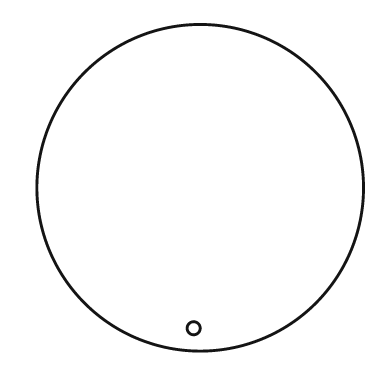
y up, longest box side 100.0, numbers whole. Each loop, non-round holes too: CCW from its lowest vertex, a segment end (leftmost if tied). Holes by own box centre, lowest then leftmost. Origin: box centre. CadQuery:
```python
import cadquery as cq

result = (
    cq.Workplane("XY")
    .moveTo(0.0, 0.0)
    .circle(50.0)
    .moveTo(-2.0, -43.0)
    .circle(2.0)
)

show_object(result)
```